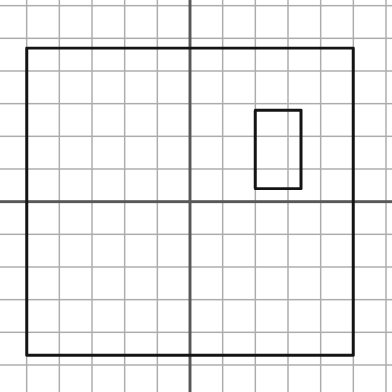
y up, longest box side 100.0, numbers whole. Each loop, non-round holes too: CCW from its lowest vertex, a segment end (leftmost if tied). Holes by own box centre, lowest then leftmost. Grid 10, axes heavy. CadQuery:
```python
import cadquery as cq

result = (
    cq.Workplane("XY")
    .moveTo(-50.0, -47.0)
    .lineTo(50.0, -47.0)
    .lineTo(50.0, 47.0)
    .lineTo(-50.0, 47.0)
    .close()
    .moveTo(20.0, 4.0)
    .lineTo(34.0, 4.0)
    .lineTo(34.0, 28.0)
    .lineTo(20.0, 28.0)
    .close()
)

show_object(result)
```